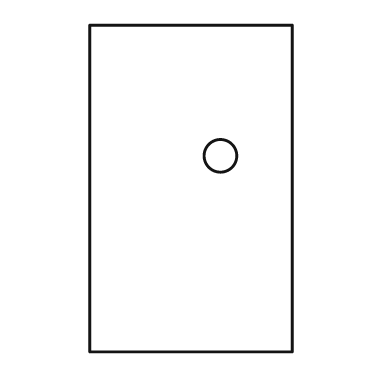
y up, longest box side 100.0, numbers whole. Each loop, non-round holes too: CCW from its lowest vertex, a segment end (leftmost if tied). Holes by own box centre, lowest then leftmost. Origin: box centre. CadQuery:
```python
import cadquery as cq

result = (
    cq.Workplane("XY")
    .moveTo(-31.0, -50.0)
    .lineTo(31.0, -50.0)
    .lineTo(31.0, 50.0)
    .lineTo(-31.0, 50.0)
    .close()
    .moveTo(9.0, 10.0)
    .circle(5.0)
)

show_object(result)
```